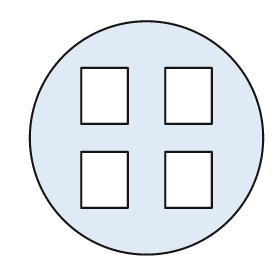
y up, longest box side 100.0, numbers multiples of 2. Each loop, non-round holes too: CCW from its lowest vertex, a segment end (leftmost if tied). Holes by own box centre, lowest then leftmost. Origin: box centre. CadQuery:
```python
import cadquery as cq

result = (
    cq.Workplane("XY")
    .moveTo(0.0, 0.0)
    .circle(50.0)
    .moveTo(-28.0, -30.0)
    .lineTo(-8.0, -30.0)
    .lineTo(-8.0, -6.0)
    .lineTo(-28.0, -6.0)
    .close()
    .moveTo(8.0, -30.0)
    .lineTo(28.0, -30.0)
    .lineTo(28.0, -6.0)
    .lineTo(8.0, -6.0)
    .close()
    .moveTo(-28.0, 6.0)
    .lineTo(-8.0, 6.0)
    .lineTo(-8.0, 30.0)
    .lineTo(-28.0, 30.0)
    .close()
    .moveTo(8.0, 6.0)
    .lineTo(28.0, 6.0)
    .lineTo(28.0, 30.0)
    .lineTo(8.0, 30.0)
    .close()
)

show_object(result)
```